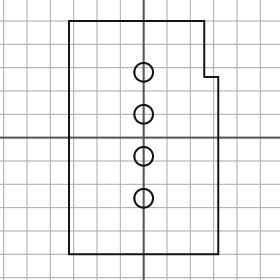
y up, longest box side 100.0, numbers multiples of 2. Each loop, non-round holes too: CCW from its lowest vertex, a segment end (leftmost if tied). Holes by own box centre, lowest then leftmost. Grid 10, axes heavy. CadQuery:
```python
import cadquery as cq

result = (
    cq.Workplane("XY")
    .moveTo(-32.0, -50.0)
    .lineTo(32.0, -50.0)
    .lineTo(32.0, 26.0)
    .lineTo(26.0, 26.0)
    .lineTo(26.0, 50.0)
    .lineTo(-32.0, 50.0)
    .close()
    .moveTo(0.0, -26.0)
    .circle(4.0)
    .moveTo(0.0, -8.0)
    .circle(4.0)
    .moveTo(0.0, 10.0)
    .circle(4.0)
    .moveTo(0.0, 28.0)
    .circle(4.0)
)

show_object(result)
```